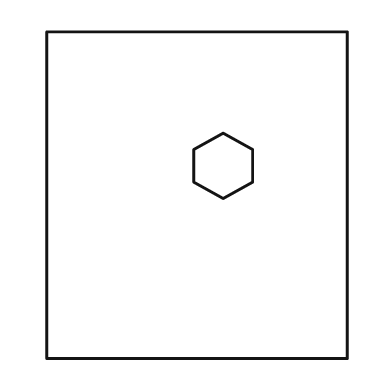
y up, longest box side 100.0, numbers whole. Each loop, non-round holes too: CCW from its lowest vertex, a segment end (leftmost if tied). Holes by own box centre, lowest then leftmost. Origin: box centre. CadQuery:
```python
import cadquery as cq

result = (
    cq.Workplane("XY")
    .moveTo(-46.0, -50.0)
    .lineTo(46.0, -50.0)
    .lineTo(46.0, 50.0)
    .lineTo(-46.0, 50.0)
    .close()
    .moveTo(8.0, -1.0)
    .lineTo(17.0, 4.0)
    .lineTo(17.0, 14.0)
    .lineTo(8.0, 19.0)
    .lineTo(-1.0, 14.0)
    .lineTo(-1.0, 4.0)
    .close()
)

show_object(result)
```